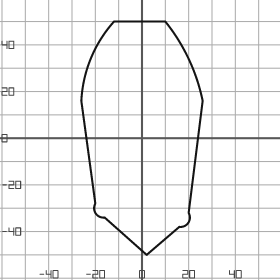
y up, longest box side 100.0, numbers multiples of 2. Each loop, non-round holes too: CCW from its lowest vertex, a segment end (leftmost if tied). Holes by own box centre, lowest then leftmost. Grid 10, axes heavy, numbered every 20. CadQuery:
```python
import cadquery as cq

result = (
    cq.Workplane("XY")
    .moveTo(2.0, -50.0)
    .lineTo(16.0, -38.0)
    .threePointArc((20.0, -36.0), (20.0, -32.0))
    .lineTo(26.0, 16.0)
    .threePointArc((20.0, 34.0), (10.0, 50.0))
    .lineTo(-12.0, 50.0)
    .threePointArc((-22.0, 34.0), (-26.0, 16.0))
    .lineTo(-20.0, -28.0)
    .threePointArc((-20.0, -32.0), (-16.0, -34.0))
    .close()
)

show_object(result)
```